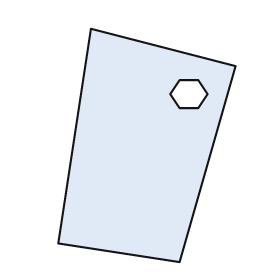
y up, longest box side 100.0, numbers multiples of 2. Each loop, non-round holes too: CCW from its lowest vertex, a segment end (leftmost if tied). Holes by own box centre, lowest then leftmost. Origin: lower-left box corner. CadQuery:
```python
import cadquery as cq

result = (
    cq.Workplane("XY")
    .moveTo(52.0, 0.0)
    .lineTo(76.0, 84.0)
    .lineTo(14.0, 100.0)
    .lineTo(0.0, 8.0)
    .close()
    .moveTo(52.0, 66.0)
    .lineTo(60.0, 66.0)
    .lineTo(64.0, 72.0)
    .lineTo(60.0, 78.0)
    .lineTo(52.0, 78.0)
    .lineTo(48.0, 72.0)
    .close()
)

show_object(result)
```